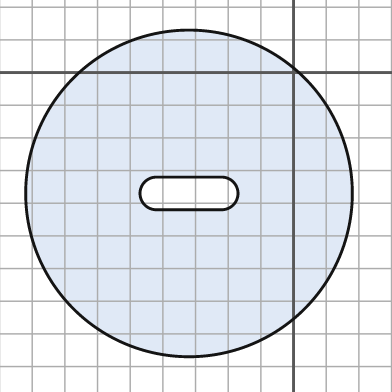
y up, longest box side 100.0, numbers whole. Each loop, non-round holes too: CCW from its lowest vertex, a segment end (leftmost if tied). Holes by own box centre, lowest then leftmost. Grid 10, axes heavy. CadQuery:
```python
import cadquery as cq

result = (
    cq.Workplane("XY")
    .moveTo(-32.0, -37.0)
    .circle(50.0)
    .moveTo(-42.0, -42.0)
    .lineTo(-22.0, -42.0)
    .threePointArc((-17.0, -37.0), (-22.0, -32.0))
    .lineTo(-42.0, -32.0)
    .threePointArc((-47.0, -37.0), (-42.0, -42.0))
    .close()
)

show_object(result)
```